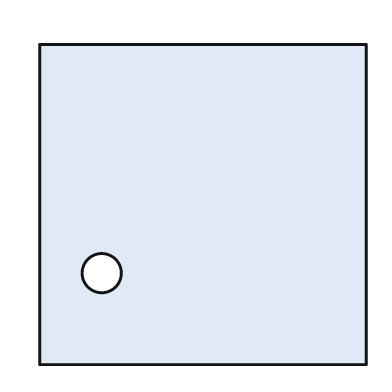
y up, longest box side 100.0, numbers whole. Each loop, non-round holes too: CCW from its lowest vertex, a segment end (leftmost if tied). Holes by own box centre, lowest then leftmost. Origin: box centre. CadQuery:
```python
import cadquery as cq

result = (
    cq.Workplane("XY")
    .moveTo(-50.0, -49.0)
    .lineTo(50.0, -49.0)
    .lineTo(50.0, 49.0)
    .lineTo(-50.0, 49.0)
    .close()
    .moveTo(-31.0, -21.0)
    .circle(6.0)
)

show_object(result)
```